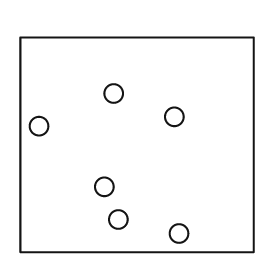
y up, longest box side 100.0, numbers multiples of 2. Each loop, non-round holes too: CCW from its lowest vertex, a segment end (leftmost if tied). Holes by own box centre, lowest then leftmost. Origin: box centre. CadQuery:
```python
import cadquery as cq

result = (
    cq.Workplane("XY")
    .moveTo(-50.0, -46.0)
    .lineTo(50.0, -46.0)
    .lineTo(50.0, 46.0)
    .lineTo(-50.0, 46.0)
    .close()
    .moveTo(18.0, -38.0)
    .circle(4.0)
    .moveTo(-8.0, -32.0)
    .circle(4.0)
    .moveTo(-14.0, -18.0)
    .circle(4.0)
    .moveTo(-42.0, 8.0)
    .circle(4.0)
    .moveTo(16.0, 12.0)
    .circle(4.0)
    .moveTo(-10.0, 22.0)
    .circle(4.0)
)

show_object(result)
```